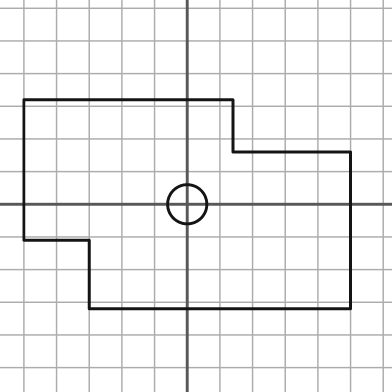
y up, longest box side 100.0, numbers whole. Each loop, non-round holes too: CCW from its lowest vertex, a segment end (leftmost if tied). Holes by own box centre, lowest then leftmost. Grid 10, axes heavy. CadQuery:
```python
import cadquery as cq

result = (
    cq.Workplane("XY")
    .moveTo(-30.0, -32.0)
    .lineTo(50.0, -32.0)
    .lineTo(50.0, 16.0)
    .lineTo(14.0, 16.0)
    .lineTo(14.0, 32.0)
    .lineTo(-50.0, 32.0)
    .lineTo(-50.0, -11.0)
    .lineTo(-30.0, -11.0)
    .close()
    .moveTo(0.0, 0.0)
    .circle(6.0)
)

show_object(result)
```